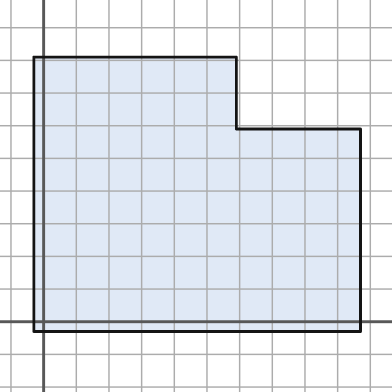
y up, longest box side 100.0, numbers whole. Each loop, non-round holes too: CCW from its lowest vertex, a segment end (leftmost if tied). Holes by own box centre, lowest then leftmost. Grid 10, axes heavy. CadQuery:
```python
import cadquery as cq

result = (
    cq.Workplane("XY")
    .moveTo(-3.0, -3.0)
    .lineTo(97.0, -3.0)
    .lineTo(97.0, 59.0)
    .lineTo(59.0, 59.0)
    .lineTo(59.0, 81.0)
    .lineTo(-3.0, 81.0)
    .close()
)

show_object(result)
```